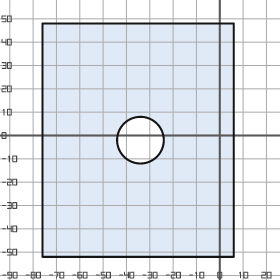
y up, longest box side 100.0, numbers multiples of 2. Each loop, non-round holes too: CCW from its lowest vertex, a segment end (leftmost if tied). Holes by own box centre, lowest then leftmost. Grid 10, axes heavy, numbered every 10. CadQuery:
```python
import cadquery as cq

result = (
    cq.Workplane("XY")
    .moveTo(-76.0, -52.0)
    .lineTo(6.0, -52.0)
    .lineTo(6.0, 48.0)
    .lineTo(-76.0, 48.0)
    .close()
    .moveTo(-34.0, -2.0)
    .circle(10.0)
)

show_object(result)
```